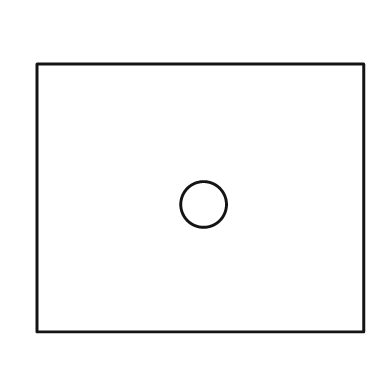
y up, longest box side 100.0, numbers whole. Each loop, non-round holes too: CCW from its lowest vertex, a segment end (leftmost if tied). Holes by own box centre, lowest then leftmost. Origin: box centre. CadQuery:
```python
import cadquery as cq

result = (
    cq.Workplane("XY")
    .moveTo(-50.0, -41.0)
    .lineTo(50.0, -41.0)
    .lineTo(50.0, 41.0)
    .lineTo(-50.0, 41.0)
    .close()
    .moveTo(1.0, -2.0)
    .circle(7.0)
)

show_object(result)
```